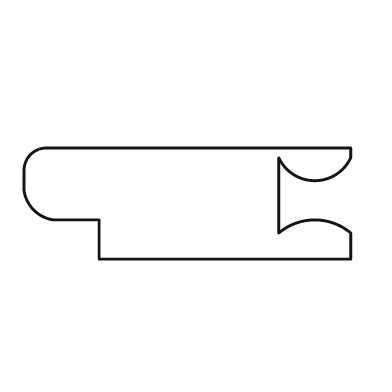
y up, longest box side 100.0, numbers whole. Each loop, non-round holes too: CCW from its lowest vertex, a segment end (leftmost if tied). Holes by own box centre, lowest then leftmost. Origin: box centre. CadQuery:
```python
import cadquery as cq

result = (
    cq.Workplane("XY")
    .moveTo(-27.0, -17.0)
    .lineTo(50.0, -17.0)
    .lineTo(50.0, -9.0)
    .threePointArc((39.0, -5.0), (28.0, -9.0))
    .lineTo(28.0, 14.0)
    .threePointArc((39.0, 7.0), (50.0, 14.0))
    .lineTo(50.0, 17.0)
    .lineTo(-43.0, 17.0)
    .threePointArc((-48.0, 15.0), (-50.0, 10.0))
    .lineTo(-50.0, 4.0)
    .threePointArc((-47.0, -2.0), (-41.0, -5.0))
    .lineTo(-27.0, -5.0)
    .close()
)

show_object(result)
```